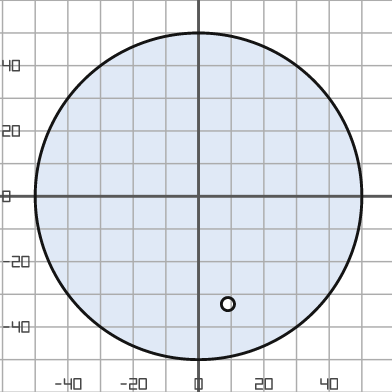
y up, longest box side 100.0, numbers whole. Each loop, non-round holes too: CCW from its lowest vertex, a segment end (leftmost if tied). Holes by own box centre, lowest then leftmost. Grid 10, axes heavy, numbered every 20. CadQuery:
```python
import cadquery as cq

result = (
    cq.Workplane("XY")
    .moveTo(0.0, 0.0)
    .circle(50.0)
    .moveTo(9.0, -33.0)
    .circle(2.0)
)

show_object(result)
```